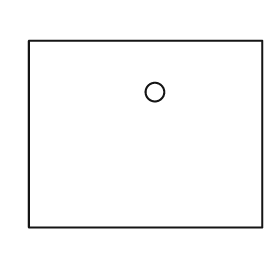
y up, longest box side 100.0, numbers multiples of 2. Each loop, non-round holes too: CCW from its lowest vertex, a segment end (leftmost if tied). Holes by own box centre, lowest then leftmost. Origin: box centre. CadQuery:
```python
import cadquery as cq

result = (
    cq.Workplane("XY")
    .moveTo(-50.0, -40.0)
    .lineTo(50.0, -40.0)
    .lineTo(50.0, 40.0)
    .lineTo(-50.0, 40.0)
    .close()
    .moveTo(4.0, 18.0)
    .circle(4.0)
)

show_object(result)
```